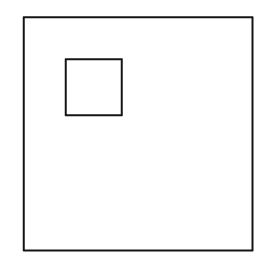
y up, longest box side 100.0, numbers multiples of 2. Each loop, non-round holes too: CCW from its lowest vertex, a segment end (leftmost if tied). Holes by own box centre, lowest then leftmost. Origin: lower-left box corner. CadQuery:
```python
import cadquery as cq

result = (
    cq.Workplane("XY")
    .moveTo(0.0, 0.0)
    .lineTo(98.0, 0.0)
    .lineTo(98.0, 100.0)
    .lineTo(0.0, 100.0)
    .close()
    .moveTo(18.0, 58.0)
    .lineTo(42.0, 58.0)
    .lineTo(42.0, 82.0)
    .lineTo(18.0, 82.0)
    .close()
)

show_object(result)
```